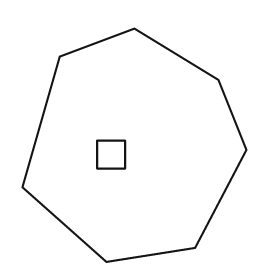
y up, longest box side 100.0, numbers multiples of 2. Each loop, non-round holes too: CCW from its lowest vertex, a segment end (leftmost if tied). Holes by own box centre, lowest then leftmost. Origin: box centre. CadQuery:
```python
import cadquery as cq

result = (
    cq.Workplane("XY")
    .moveTo(-12.0, -50.0)
    .lineTo(26.0, -44.0)
    .lineTo(48.0, -2.0)
    .lineTo(36.0, 28.0)
    .lineTo(0.0, 50.0)
    .lineTo(-32.0, 38.0)
    .lineTo(-48.0, -18.0)
    .close()
    .moveTo(-16.0, -10.0)
    .lineTo(-4.0, -10.0)
    .lineTo(-4.0, 2.0)
    .lineTo(-16.0, 2.0)
    .close()
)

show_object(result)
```